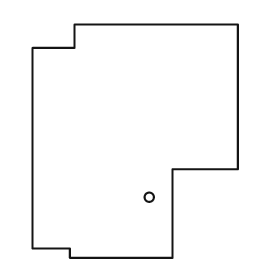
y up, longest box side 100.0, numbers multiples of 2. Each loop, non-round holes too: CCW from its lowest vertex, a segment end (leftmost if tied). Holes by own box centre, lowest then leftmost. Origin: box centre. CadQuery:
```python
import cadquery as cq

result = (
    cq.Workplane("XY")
    .moveTo(-28.0, -50.0)
    .lineTo(16.0, -50.0)
    .lineTo(16.0, -12.0)
    .lineTo(44.0, -12.0)
    .lineTo(44.0, 50.0)
    .lineTo(-26.0, 50.0)
    .lineTo(-26.0, 40.0)
    .lineTo(-44.0, 40.0)
    .lineTo(-44.0, -46.0)
    .lineTo(-28.0, -46.0)
    .close()
    .moveTo(6.0, -24.0)
    .circle(2.0)
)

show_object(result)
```